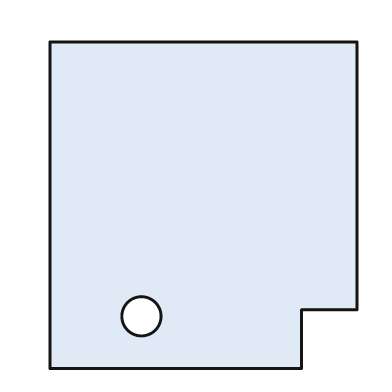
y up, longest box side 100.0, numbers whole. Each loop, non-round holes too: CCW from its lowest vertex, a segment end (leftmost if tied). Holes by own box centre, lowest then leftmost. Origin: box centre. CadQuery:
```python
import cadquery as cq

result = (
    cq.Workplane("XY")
    .moveTo(-47.0, -50.0)
    .lineTo(30.0, -50.0)
    .lineTo(30.0, -32.0)
    .lineTo(47.0, -32.0)
    .lineTo(47.0, 50.0)
    .lineTo(-47.0, 50.0)
    .close()
    .moveTo(-19.0, -34.0)
    .circle(6.0)
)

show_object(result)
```